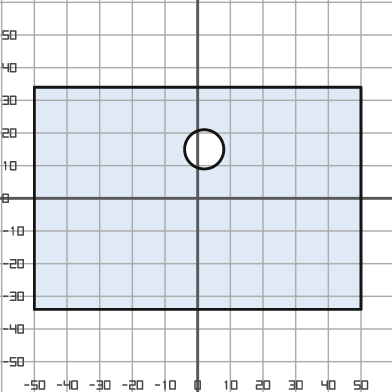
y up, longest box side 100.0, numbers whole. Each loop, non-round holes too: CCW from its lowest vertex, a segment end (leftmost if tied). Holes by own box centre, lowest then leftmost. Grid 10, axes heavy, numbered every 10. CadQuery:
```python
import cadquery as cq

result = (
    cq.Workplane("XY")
    .moveTo(-50.0, -34.0)
    .lineTo(50.0, -34.0)
    .lineTo(50.0, 34.0)
    .lineTo(-50.0, 34.0)
    .close()
    .moveTo(2.0, 15.0)
    .circle(6.0)
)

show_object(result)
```